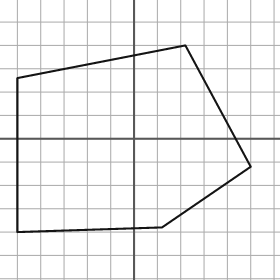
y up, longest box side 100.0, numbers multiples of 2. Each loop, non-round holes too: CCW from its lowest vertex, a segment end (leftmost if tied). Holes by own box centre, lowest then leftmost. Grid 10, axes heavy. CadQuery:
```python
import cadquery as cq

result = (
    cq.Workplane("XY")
    .moveTo(-50.0, -40.0)
    .lineTo(12.0, -38.0)
    .lineTo(50.0, -12.0)
    .lineTo(22.0, 40.0)
    .lineTo(-50.0, 26.0)
    .close()
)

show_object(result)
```